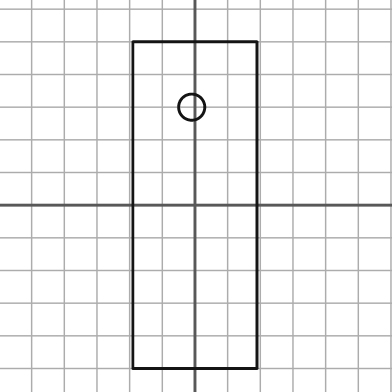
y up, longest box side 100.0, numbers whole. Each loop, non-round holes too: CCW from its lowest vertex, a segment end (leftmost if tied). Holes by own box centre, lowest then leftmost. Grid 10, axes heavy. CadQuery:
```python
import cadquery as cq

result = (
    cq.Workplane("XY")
    .moveTo(-19.0, -50.0)
    .lineTo(19.0, -50.0)
    .lineTo(19.0, 50.0)
    .lineTo(-19.0, 50.0)
    .close()
    .moveTo(-1.0, 30.0)
    .circle(4.0)
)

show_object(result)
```